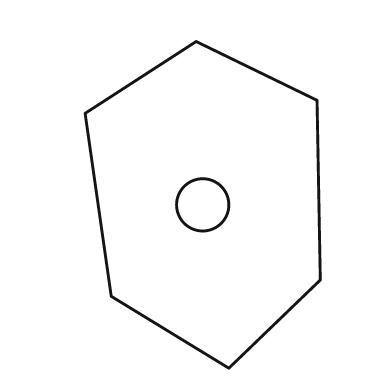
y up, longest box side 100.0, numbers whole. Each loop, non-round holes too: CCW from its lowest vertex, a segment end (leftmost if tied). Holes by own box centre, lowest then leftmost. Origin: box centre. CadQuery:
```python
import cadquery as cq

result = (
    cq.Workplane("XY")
    .moveTo(8.0, -50.0)
    .lineTo(36.0, -23.0)
    .lineTo(35.0, 32.0)
    .lineTo(-2.0, 50.0)
    .lineTo(-36.0, 28.0)
    .lineTo(-28.0, -28.0)
    .close()
    .moveTo(0.0, 0.0)
    .circle(8.0)
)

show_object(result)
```